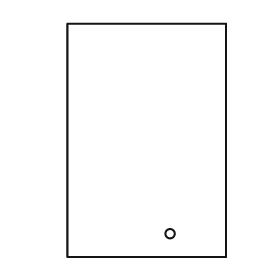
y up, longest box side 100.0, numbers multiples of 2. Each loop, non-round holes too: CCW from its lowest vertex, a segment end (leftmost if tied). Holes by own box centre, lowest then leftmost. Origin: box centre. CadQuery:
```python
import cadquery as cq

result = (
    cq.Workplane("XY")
    .moveTo(-34.0, -50.0)
    .lineTo(34.0, -50.0)
    .lineTo(34.0, 50.0)
    .lineTo(-34.0, 50.0)
    .close()
    .moveTo(10.0, -40.0)
    .circle(2.0)
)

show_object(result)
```